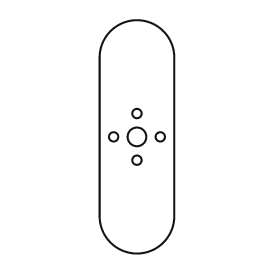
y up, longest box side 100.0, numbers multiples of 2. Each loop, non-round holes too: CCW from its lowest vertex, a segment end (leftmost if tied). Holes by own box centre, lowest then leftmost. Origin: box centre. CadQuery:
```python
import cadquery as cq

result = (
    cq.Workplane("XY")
    .moveTo(-16.0, -34.0)
    .threePointArc((0.0, -50.0), (16.0, -34.0))
    .lineTo(16.0, 34.0)
    .threePointArc((0.0, 50.0), (-16.0, 34.0))
    .close()
    .moveTo(0.0, -10.0)
    .circle(2.0)
    .moveTo(-10.0, 0.0)
    .circle(2.0)
    .moveTo(0.0, 0.0)
    .circle(4.0)
    .moveTo(10.0, 0.0)
    .circle(2.0)
    .moveTo(0.0, 10.0)
    .circle(2.0)
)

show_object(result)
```